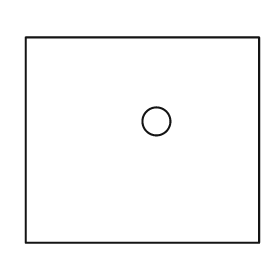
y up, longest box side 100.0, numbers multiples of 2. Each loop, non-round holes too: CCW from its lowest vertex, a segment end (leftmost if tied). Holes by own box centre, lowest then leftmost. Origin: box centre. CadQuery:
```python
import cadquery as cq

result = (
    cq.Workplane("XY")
    .moveTo(-50.0, -44.0)
    .lineTo(50.0, -44.0)
    .lineTo(50.0, 44.0)
    .lineTo(-50.0, 44.0)
    .close()
    .moveTo(6.0, 8.0)
    .circle(6.0)
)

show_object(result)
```